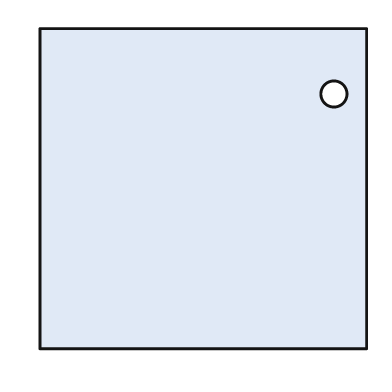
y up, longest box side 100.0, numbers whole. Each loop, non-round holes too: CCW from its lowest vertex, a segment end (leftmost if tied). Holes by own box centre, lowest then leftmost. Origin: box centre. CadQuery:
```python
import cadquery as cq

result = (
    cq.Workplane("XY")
    .moveTo(-50.0, -49.0)
    .lineTo(50.0, -49.0)
    .lineTo(50.0, 49.0)
    .lineTo(-50.0, 49.0)
    .close()
    .moveTo(40.0, 29.0)
    .circle(4.0)
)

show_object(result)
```